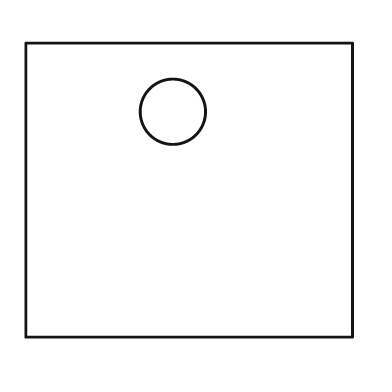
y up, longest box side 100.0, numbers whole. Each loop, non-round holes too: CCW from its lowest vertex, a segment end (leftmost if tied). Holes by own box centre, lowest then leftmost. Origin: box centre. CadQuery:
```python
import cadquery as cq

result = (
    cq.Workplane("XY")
    .moveTo(-50.0, -45.0)
    .lineTo(50.0, -45.0)
    .lineTo(50.0, 45.0)
    .lineTo(-50.0, 45.0)
    .close()
    .moveTo(-5.0, 24.0)
    .circle(10.0)
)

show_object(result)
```